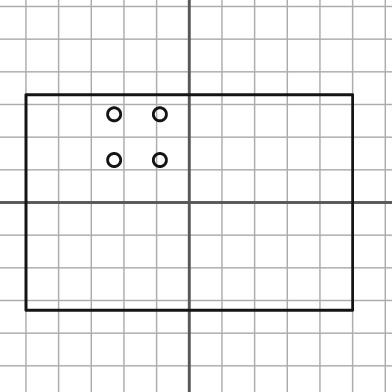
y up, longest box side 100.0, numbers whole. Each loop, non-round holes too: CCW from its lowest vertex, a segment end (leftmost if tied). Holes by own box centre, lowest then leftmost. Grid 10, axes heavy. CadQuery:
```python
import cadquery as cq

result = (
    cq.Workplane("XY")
    .moveTo(-50.0, -33.0)
    .lineTo(50.0, -33.0)
    .lineTo(50.0, 33.0)
    .lineTo(-50.0, 33.0)
    .close()
    .moveTo(-23.0, 13.0)
    .circle(2.0)
    .moveTo(-9.0, 13.0)
    .circle(2.0)
    .moveTo(-23.0, 27.0)
    .circle(2.0)
    .moveTo(-9.0, 27.0)
    .circle(2.0)
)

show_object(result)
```